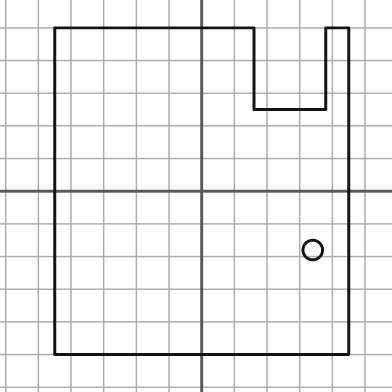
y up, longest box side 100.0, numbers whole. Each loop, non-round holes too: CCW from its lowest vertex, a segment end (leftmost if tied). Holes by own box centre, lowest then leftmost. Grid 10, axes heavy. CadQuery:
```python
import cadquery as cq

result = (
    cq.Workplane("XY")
    .moveTo(-45.0, -50.0)
    .lineTo(45.0, -50.0)
    .lineTo(45.0, 50.0)
    .lineTo(38.0, 50.0)
    .lineTo(38.0, 25.0)
    .lineTo(16.0, 25.0)
    .lineTo(16.0, 50.0)
    .lineTo(-45.0, 50.0)
    .close()
    .moveTo(34.0, -18.0)
    .circle(3.0)
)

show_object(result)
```